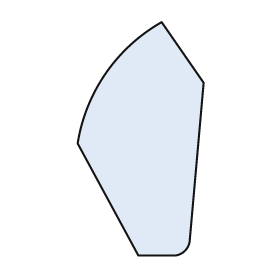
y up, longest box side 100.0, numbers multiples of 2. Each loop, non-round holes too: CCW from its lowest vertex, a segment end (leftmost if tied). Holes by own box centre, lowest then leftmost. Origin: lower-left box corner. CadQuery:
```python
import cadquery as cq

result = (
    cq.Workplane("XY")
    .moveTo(26.0, 0.0)
    .lineTo(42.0, 0.0)
    .threePointArc((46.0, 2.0), (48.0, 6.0))
    .lineTo(54.0, 74.0)
    .lineTo(36.0, 100.0)
    .threePointArc((12.0, 78.0), (0.0, 48.0))
    .close()
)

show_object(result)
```